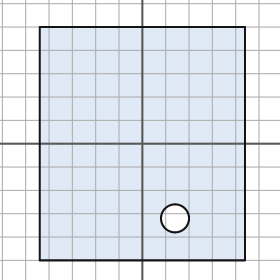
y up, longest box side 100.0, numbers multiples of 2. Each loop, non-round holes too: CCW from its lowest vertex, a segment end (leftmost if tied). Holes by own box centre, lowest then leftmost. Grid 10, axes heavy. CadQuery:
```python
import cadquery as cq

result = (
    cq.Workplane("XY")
    .moveTo(-44.0, -50.0)
    .lineTo(44.0, -50.0)
    .lineTo(44.0, 50.0)
    .lineTo(-44.0, 50.0)
    .close()
    .moveTo(14.0, -32.0)
    .circle(6.0)
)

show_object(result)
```